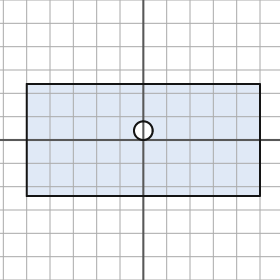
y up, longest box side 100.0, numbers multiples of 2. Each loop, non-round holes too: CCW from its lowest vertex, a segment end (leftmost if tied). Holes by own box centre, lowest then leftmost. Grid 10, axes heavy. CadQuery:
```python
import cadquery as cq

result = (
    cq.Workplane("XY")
    .moveTo(-50.0, -24.0)
    .lineTo(50.0, -24.0)
    .lineTo(50.0, 24.0)
    .lineTo(-50.0, 24.0)
    .close()
    .moveTo(0.0, 4.0)
    .circle(4.0)
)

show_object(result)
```